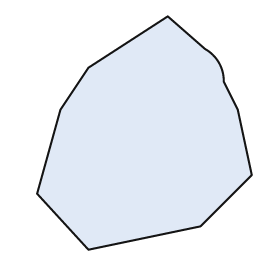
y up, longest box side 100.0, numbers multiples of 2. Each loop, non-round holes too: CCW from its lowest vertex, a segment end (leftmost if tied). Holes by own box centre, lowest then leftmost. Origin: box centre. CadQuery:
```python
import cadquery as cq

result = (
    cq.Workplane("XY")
    .moveTo(-24.0, -50.0)
    .lineTo(24.0, -40.0)
    .lineTo(46.0, -18.0)
    .lineTo(40.0, 10.0)
    .lineTo(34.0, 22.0)
    .threePointArc((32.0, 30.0), (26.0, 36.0))
    .lineTo(10.0, 50.0)
    .lineTo(-24.0, 28.0)
    .lineTo(-36.0, 10.0)
    .lineTo(-46.0, -26.0)
    .close()
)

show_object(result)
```